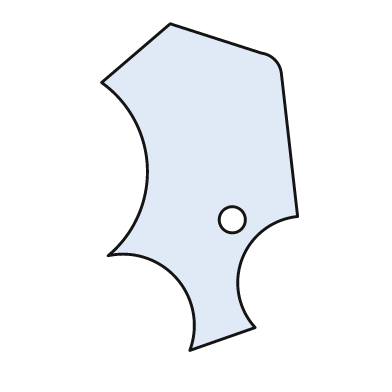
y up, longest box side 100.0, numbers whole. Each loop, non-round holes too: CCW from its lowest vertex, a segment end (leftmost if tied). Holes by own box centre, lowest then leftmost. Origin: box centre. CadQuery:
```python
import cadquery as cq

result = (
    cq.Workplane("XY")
    .moveTo(-3.0, -50.0)
    .lineTo(17.0, -43.0)
    .threePointArc((13.0, -22.0), (30.0, -9.0))
    .lineTo(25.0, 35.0)
    .threePointArc((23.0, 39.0), (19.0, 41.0))
    .lineTo(-9.0, 50.0)
    .lineTo(-30.0, 32.0)
    .threePointArc((-16.0, 6.0), (-28.0, -21.0))
    .threePointArc((-7.0, -28.0), (-3.0, -50.0))
    .close()
    .moveTo(10.0, -10.0)
    .circle(4.0)
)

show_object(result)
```